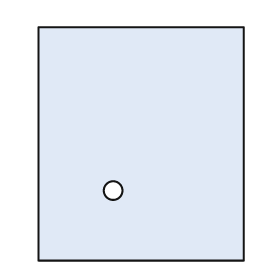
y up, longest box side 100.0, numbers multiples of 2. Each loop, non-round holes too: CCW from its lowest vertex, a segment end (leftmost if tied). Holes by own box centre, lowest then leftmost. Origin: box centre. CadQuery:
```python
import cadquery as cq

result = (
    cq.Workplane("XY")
    .moveTo(-44.0, -50.0)
    .lineTo(44.0, -50.0)
    .lineTo(44.0, 50.0)
    .lineTo(-44.0, 50.0)
    .close()
    .moveTo(-12.0, -20.0)
    .circle(4.0)
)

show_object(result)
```